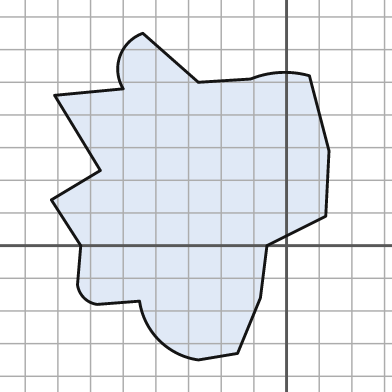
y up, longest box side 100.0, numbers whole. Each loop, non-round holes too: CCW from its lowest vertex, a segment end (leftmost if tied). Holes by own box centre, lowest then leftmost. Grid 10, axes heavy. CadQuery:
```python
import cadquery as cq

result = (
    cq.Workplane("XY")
    .moveTo(-27.0, -35.0)
    .lineTo(-15.0, -33.0)
    .lineTo(-8.0, -16.0)
    .lineTo(-6.0, 0.0)
    .lineTo(12.0, 9.0)
    .lineTo(13.0, 29.0)
    .lineTo(7.0, 52.0)
    .threePointArc((-2.0, 53.0), (-11.0, 51.0))
    .lineTo(-27.0, 50.0)
    .lineTo(-44.0, 65.0)
    .threePointArc((-51.0, 58.0), (-50.0, 48.0))
    .lineTo(-71.0, 46.0)
    .lineTo(-57.0, 23.0)
    .lineTo(-72.0, 14.0)
    .lineTo(-63.0, 0.0)
    .lineTo(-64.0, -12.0)
    .threePointArc((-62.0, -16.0), (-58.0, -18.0))
    .lineTo(-45.0, -17.0)
    .threePointArc((-39.0, -29.0), (-27.0, -35.0))
    .close()
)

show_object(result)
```